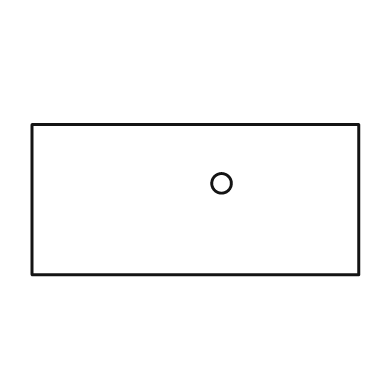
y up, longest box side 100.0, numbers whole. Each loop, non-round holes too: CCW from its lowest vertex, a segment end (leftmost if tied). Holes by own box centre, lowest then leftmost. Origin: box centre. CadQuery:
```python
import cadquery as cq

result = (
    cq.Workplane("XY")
    .moveTo(-50.0, -23.0)
    .lineTo(50.0, -23.0)
    .lineTo(50.0, 23.0)
    .lineTo(-50.0, 23.0)
    .close()
    .moveTo(8.0, 5.0)
    .circle(3.0)
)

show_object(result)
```